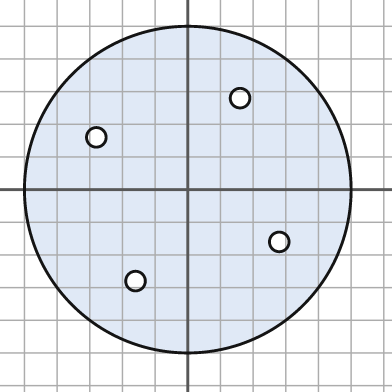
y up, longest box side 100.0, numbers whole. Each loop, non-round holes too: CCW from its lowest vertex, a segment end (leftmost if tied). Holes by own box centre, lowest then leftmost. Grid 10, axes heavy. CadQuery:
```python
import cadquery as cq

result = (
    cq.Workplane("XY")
    .moveTo(0.0, 0.0)
    .circle(50.0)
    .moveTo(-16.0, -28.0)
    .circle(3.0)
    .moveTo(28.0, -16.0)
    .circle(3.0)
    .moveTo(-28.0, 16.0)
    .circle(3.0)
    .moveTo(16.0, 28.0)
    .circle(3.0)
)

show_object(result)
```